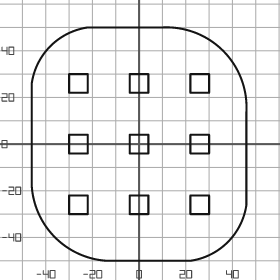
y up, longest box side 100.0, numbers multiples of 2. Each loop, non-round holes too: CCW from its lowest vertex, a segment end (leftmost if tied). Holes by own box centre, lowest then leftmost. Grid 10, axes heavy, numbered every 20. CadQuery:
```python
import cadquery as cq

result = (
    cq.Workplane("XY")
    .moveTo(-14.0, -50.0)
    .lineTo(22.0, -50.0)
    .threePointArc((38.0, -42.0), (46.0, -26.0))
    .lineTo(46.0, 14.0)
    .threePointArc((36.0, 40.0), (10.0, 50.0))
    .lineTo(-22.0, 50.0)
    .threePointArc((-38.0, 42.0), (-46.0, 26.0))
    .lineTo(-46.0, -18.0)
    .threePointArc((-36.0, -40.0), (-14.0, -50.0))
    .close()
    .moveTo(-30.0, -30.0)
    .lineTo(-22.0, -30.0)
    .lineTo(-22.0, -22.0)
    .lineTo(-30.0, -22.0)
    .close()
    .moveTo(-4.0, -30.0)
    .lineTo(4.0, -30.0)
    .lineTo(4.0, -22.0)
    .lineTo(-4.0, -22.0)
    .close()
    .moveTo(22.0, -30.0)
    .lineTo(30.0, -30.0)
    .lineTo(30.0, -22.0)
    .lineTo(22.0, -22.0)
    .close()
    .moveTo(-30.0, -4.0)
    .lineTo(-22.0, -4.0)
    .lineTo(-22.0, 4.0)
    .lineTo(-30.0, 4.0)
    .close()
    .moveTo(-4.0, -4.0)
    .lineTo(4.0, -4.0)
    .lineTo(4.0, 4.0)
    .lineTo(-4.0, 4.0)
    .close()
    .moveTo(22.0, -4.0)
    .lineTo(30.0, -4.0)
    .lineTo(30.0, 4.0)
    .lineTo(22.0, 4.0)
    .close()
    .moveTo(-30.0, 22.0)
    .lineTo(-22.0, 22.0)
    .lineTo(-22.0, 30.0)
    .lineTo(-30.0, 30.0)
    .close()
    .moveTo(-4.0, 22.0)
    .lineTo(4.0, 22.0)
    .lineTo(4.0, 30.0)
    .lineTo(-4.0, 30.0)
    .close()
    .moveTo(22.0, 22.0)
    .lineTo(30.0, 22.0)
    .lineTo(30.0, 30.0)
    .lineTo(22.0, 30.0)
    .close()
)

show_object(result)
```